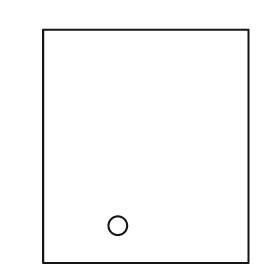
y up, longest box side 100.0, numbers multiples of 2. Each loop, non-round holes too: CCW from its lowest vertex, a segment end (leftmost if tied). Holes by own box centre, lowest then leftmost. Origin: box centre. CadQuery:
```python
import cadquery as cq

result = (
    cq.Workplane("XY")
    .moveTo(-44.0, -50.0)
    .lineTo(44.0, -50.0)
    .lineTo(44.0, 50.0)
    .lineTo(-44.0, 50.0)
    .close()
    .moveTo(-12.0, -34.0)
    .circle(4.0)
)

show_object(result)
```